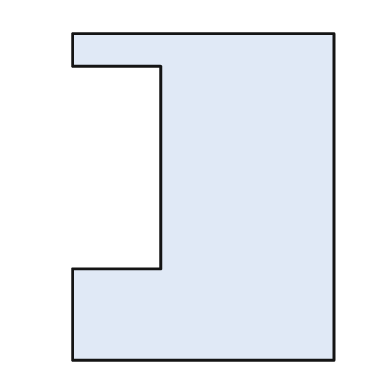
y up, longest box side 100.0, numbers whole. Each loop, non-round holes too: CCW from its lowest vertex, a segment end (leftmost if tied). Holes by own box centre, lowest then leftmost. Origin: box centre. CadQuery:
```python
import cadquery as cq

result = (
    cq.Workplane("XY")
    .moveTo(-40.0, -50.0)
    .lineTo(40.0, -50.0)
    .lineTo(40.0, 50.0)
    .lineTo(-40.0, 50.0)
    .lineTo(-40.0, 40.0)
    .lineTo(-13.0, 40.0)
    .lineTo(-13.0, -22.0)
    .lineTo(-40.0, -22.0)
    .close()
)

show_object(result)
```